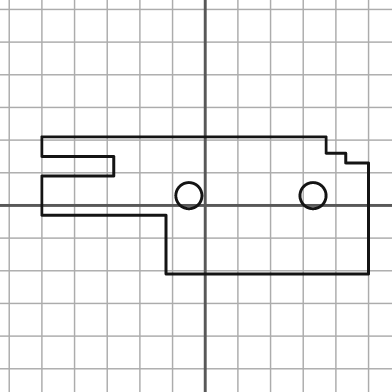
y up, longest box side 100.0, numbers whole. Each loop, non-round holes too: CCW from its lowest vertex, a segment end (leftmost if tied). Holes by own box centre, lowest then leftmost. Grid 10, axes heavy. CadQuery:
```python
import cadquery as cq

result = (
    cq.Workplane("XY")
    .moveTo(-12.0, -21.0)
    .lineTo(50.0, -21.0)
    .lineTo(50.0, 13.0)
    .lineTo(43.0, 13.0)
    .lineTo(43.0, 16.0)
    .lineTo(37.0, 16.0)
    .lineTo(37.0, 21.0)
    .lineTo(-50.0, 21.0)
    .lineTo(-50.0, 15.0)
    .lineTo(-28.0, 15.0)
    .lineTo(-28.0, 9.0)
    .lineTo(-50.0, 9.0)
    .lineTo(-50.0, -3.0)
    .lineTo(-12.0, -3.0)
    .close()
    .moveTo(-5.0, 3.0)
    .circle(4.0)
    .moveTo(33.0, 3.0)
    .circle(4.0)
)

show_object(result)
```